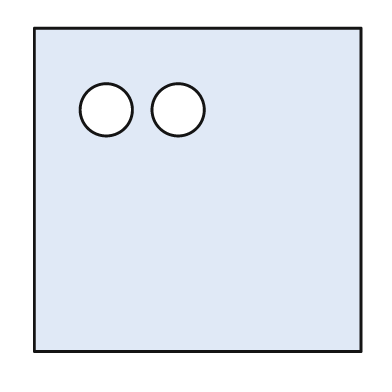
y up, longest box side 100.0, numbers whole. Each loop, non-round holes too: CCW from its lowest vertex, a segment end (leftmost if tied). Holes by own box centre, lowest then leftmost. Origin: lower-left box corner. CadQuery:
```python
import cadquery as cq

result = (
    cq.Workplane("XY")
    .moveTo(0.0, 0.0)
    .lineTo(100.0, 0.0)
    .lineTo(100.0, 99.0)
    .lineTo(0.0, 99.0)
    .close()
    .moveTo(22.0, 74.0)
    .circle(8.0)
    .moveTo(44.0, 74.0)
    .circle(8.0)
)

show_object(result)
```